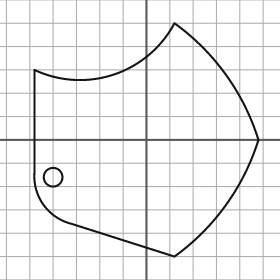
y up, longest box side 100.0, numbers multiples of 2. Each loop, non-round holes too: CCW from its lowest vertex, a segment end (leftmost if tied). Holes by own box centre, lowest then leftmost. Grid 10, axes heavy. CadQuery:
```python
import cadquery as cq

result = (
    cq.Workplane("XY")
    .moveTo(12.0, -50.0)
    .threePointArc((34.0, -28.0), (48.0, 0.0))
    .threePointArc((34.0, 28.0), (12.0, 50.0))
    .threePointArc((-14.0, 28.0), (-48.0, 30.0))
    .lineTo(-48.0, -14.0)
    .threePointArc((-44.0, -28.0), (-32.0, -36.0))
    .close()
    .moveTo(-40.0, -16.0)
    .circle(4.0)
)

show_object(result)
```